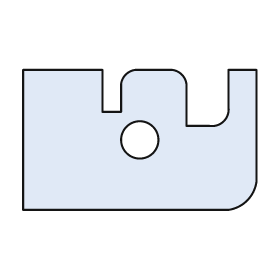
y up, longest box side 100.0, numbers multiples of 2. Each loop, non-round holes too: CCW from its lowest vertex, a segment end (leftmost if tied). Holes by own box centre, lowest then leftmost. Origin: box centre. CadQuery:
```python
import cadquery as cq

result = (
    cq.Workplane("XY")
    .moveTo(-50.0, -30.0)
    .lineTo(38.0, -30.0)
    .threePointArc((46.0, -26.0), (50.0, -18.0))
    .lineTo(50.0, 30.0)
    .lineTo(38.0, 30.0)
    .lineTo(38.0, 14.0)
    .threePointArc((36.0, 8.0), (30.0, 6.0))
    .lineTo(20.0, 6.0)
    .lineTo(20.0, 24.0)
    .threePointArc((18.0, 28.0), (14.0, 30.0))
    .lineTo(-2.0, 30.0)
    .threePointArc((-6.0, 28.0), (-8.0, 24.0))
    .lineTo(-8.0, 12.0)
    .lineTo(-16.0, 12.0)
    .lineTo(-16.0, 30.0)
    .lineTo(-50.0, 30.0)
    .close()
    .moveTo(0.0, 0.0)
    .circle(8.0)
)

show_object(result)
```